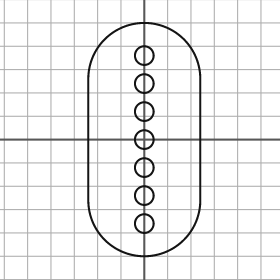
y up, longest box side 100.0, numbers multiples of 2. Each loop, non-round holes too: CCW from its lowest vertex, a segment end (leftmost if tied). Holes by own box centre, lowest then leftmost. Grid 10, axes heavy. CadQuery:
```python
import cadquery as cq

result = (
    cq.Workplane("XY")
    .moveTo(-24.0, -26.0)
    .threePointArc((0.0, -50.0), (24.0, -26.0))
    .lineTo(24.0, 26.0)
    .threePointArc((0.0, 50.0), (-24.0, 26.0))
    .close()
    .moveTo(0.0, -36.0)
    .circle(4.0)
    .moveTo(0.0, -24.0)
    .circle(4.0)
    .moveTo(0.0, -12.0)
    .circle(4.0)
    .moveTo(0.0, 0.0)
    .circle(4.0)
    .moveTo(0.0, 12.0)
    .circle(4.0)
    .moveTo(0.0, 24.0)
    .circle(4.0)
    .moveTo(0.0, 36.0)
    .circle(4.0)
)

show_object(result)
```